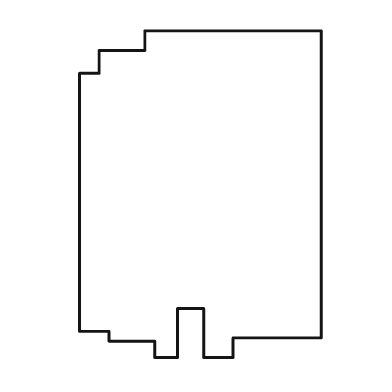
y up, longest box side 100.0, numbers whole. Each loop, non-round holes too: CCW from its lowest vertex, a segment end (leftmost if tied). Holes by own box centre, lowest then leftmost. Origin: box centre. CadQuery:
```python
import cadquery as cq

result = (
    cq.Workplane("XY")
    .moveTo(-14.0, -50.0)
    .lineTo(-7.0, -50.0)
    .lineTo(-7.0, -35.0)
    .lineTo(1.0, -35.0)
    .lineTo(1.0, -50.0)
    .lineTo(10.0, -50.0)
    .lineTo(10.0, -44.0)
    .lineTo(37.0, -44.0)
    .lineTo(37.0, 50.0)
    .lineTo(-17.0, 50.0)
    .lineTo(-17.0, 44.0)
    .lineTo(-31.0, 44.0)
    .lineTo(-31.0, 37.0)
    .lineTo(-37.0, 37.0)
    .lineTo(-37.0, -42.0)
    .lineTo(-28.0, -42.0)
    .lineTo(-28.0, -45.0)
    .lineTo(-14.0, -45.0)
    .close()
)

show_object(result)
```